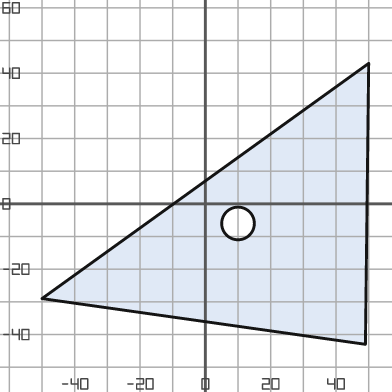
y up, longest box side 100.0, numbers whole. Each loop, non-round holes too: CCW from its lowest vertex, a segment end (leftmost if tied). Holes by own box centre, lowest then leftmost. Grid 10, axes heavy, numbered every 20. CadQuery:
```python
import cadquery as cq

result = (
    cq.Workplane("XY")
    .moveTo(49.0, -43.0)
    .lineTo(50.0, 43.0)
    .lineTo(-50.0, -29.0)
    .close()
    .moveTo(10.0, -6.0)
    .circle(5.0)
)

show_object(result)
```